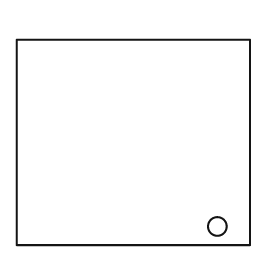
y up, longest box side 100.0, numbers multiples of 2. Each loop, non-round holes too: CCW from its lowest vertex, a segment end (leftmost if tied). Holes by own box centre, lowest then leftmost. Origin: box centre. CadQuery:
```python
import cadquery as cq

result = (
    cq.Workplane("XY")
    .moveTo(-50.0, -44.0)
    .lineTo(50.0, -44.0)
    .lineTo(50.0, 44.0)
    .lineTo(-50.0, 44.0)
    .close()
    .moveTo(36.0, -36.0)
    .circle(4.0)
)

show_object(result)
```